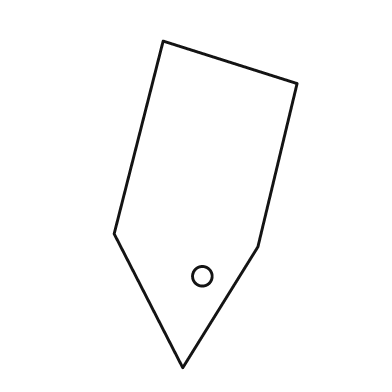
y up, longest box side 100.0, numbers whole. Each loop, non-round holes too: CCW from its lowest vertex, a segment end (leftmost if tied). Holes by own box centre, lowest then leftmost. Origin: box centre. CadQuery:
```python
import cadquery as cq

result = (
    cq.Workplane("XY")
    .moveTo(-7.0, -50.0)
    .lineTo(16.0, -13.0)
    .lineTo(28.0, 37.0)
    .lineTo(-13.0, 50.0)
    .lineTo(-28.0, -9.0)
    .close()
    .moveTo(-1.0, -22.0)
    .circle(3.0)
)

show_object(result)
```